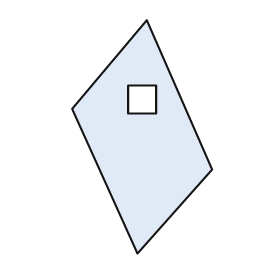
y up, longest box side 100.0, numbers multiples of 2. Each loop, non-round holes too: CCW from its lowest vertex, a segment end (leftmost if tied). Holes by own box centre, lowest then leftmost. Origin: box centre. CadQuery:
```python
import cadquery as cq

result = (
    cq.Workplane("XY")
    .moveTo(-2.0, -50.0)
    .lineTo(30.0, -14.0)
    .lineTo(2.0, 50.0)
    .lineTo(-30.0, 12.0)
    .close()
    .moveTo(-6.0, 10.0)
    .lineTo(6.0, 10.0)
    .lineTo(6.0, 22.0)
    .lineTo(-6.0, 22.0)
    .close()
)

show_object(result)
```